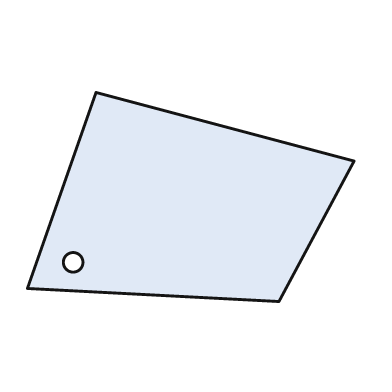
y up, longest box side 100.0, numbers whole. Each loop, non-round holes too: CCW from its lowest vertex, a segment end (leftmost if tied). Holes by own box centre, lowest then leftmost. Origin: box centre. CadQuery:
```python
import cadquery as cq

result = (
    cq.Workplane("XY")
    .moveTo(27.0, -32.0)
    .lineTo(50.0, 11.0)
    .lineTo(-29.0, 32.0)
    .lineTo(-50.0, -28.0)
    .close()
    .moveTo(-36.0, -20.0)
    .circle(3.0)
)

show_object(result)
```